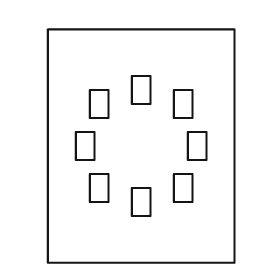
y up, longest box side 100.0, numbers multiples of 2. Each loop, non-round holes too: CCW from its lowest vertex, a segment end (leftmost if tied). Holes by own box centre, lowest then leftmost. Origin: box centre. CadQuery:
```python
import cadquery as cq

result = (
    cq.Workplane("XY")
    .moveTo(-40.0, -50.0)
    .lineTo(40.0, -50.0)
    .lineTo(40.0, 50.0)
    .lineTo(-40.0, 50.0)
    .close()
    .moveTo(-4.0, -30.0)
    .lineTo(4.0, -30.0)
    .lineTo(4.0, -18.0)
    .lineTo(-4.0, -18.0)
    .close()
    .moveTo(-22.0, -24.0)
    .lineTo(-14.0, -24.0)
    .lineTo(-14.0, -12.0)
    .lineTo(-22.0, -12.0)
    .close()
    .moveTo(14.0, -24.0)
    .lineTo(22.0, -24.0)
    .lineTo(22.0, -12.0)
    .lineTo(14.0, -12.0)
    .close()
    .moveTo(-28.0, -6.0)
    .lineTo(-20.0, -6.0)
    .lineTo(-20.0, 6.0)
    .lineTo(-28.0, 6.0)
    .close()
    .moveTo(20.0, -6.0)
    .lineTo(28.0, -6.0)
    .lineTo(28.0, 6.0)
    .lineTo(20.0, 6.0)
    .close()
    .moveTo(-22.0, 12.0)
    .lineTo(-14.0, 12.0)
    .lineTo(-14.0, 24.0)
    .lineTo(-22.0, 24.0)
    .close()
    .moveTo(14.0, 12.0)
    .lineTo(22.0, 12.0)
    .lineTo(22.0, 24.0)
    .lineTo(14.0, 24.0)
    .close()
    .moveTo(-4.0, 18.0)
    .lineTo(4.0, 18.0)
    .lineTo(4.0, 30.0)
    .lineTo(-4.0, 30.0)
    .close()
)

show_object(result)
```